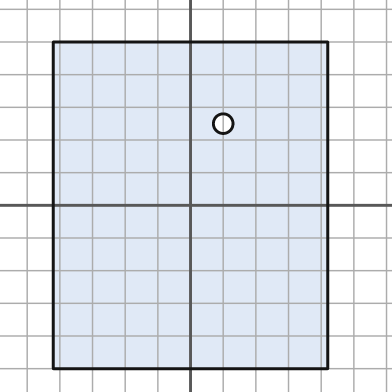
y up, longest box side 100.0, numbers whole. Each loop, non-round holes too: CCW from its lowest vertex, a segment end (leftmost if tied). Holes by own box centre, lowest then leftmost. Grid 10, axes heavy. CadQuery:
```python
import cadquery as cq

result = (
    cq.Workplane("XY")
    .moveTo(-42.0, -50.0)
    .lineTo(42.0, -50.0)
    .lineTo(42.0, 50.0)
    .lineTo(-42.0, 50.0)
    .close()
    .moveTo(10.0, 25.0)
    .circle(3.0)
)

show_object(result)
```